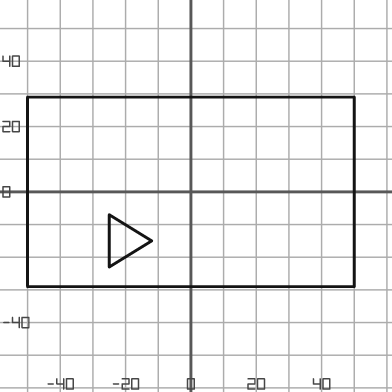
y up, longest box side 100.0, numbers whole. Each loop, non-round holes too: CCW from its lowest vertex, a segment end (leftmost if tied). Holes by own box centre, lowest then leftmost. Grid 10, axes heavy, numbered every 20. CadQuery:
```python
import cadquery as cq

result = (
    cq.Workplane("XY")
    .moveTo(-50.0, -29.0)
    .lineTo(50.0, -29.0)
    .lineTo(50.0, 29.0)
    .lineTo(-50.0, 29.0)
    .close()
    .moveTo(-25.0, -23.0)
    .lineTo(-12.0, -15.0)
    .lineTo(-25.0, -7.0)
    .close()
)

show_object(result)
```